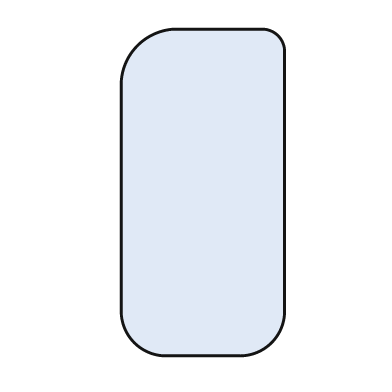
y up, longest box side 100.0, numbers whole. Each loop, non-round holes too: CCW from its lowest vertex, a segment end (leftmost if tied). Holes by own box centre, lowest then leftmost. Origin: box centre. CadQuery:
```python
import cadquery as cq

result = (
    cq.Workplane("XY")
    .moveTo(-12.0, -50.0)
    .lineTo(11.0, -50.0)
    .threePointArc((21.0, -46.0), (25.0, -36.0))
    .lineTo(25.0, 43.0)
    .threePointArc((23.0, 48.0), (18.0, 50.0))
    .lineTo(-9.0, 50.0)
    .threePointArc((-20.0, 45.0), (-25.0, 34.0))
    .lineTo(-25.0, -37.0)
    .threePointArc((-21.0, -46.0), (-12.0, -50.0))
    .close()
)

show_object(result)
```